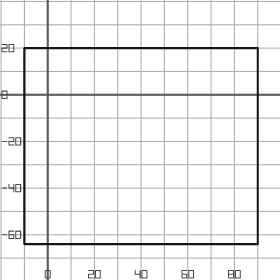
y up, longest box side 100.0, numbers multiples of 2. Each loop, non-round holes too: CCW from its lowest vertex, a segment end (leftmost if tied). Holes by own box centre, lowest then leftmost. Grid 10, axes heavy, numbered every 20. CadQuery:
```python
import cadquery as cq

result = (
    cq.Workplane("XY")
    .moveTo(-10.0, -64.0)
    .lineTo(90.0, -64.0)
    .lineTo(90.0, 20.0)
    .lineTo(-10.0, 20.0)
    .close()
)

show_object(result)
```